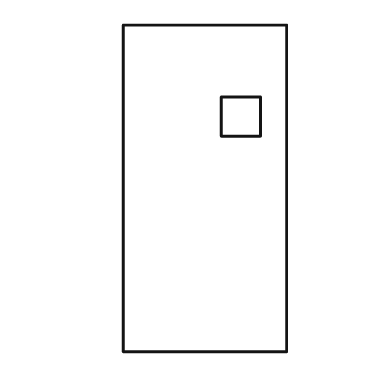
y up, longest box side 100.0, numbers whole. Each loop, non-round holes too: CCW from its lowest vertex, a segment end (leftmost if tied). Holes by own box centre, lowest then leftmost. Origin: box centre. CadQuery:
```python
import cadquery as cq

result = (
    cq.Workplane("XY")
    .moveTo(-25.0, -50.0)
    .lineTo(25.0, -50.0)
    .lineTo(25.0, 50.0)
    .lineTo(-25.0, 50.0)
    .close()
    .moveTo(5.0, 16.0)
    .lineTo(17.0, 16.0)
    .lineTo(17.0, 28.0)
    .lineTo(5.0, 28.0)
    .close()
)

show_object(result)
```